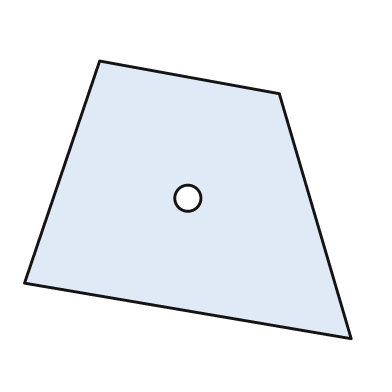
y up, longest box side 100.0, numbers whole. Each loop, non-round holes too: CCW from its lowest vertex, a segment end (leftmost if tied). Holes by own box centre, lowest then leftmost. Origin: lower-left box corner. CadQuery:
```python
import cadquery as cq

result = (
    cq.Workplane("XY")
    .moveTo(100.0, 0.0)
    .lineTo(78.0, 75.0)
    .lineTo(23.0, 85.0)
    .lineTo(0.0, 17.0)
    .close()
    .moveTo(50.0, 43.0)
    .circle(4.0)
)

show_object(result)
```